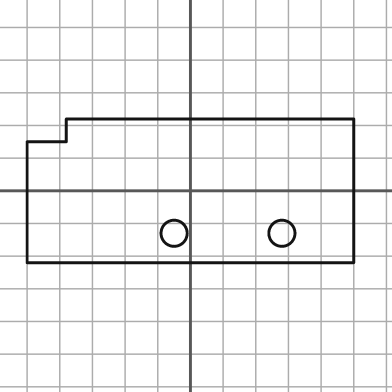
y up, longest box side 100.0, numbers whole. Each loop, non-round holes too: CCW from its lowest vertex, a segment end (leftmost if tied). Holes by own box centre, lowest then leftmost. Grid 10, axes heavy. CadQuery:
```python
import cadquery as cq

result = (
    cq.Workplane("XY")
    .moveTo(-50.0, -22.0)
    .lineTo(50.0, -22.0)
    .lineTo(50.0, 22.0)
    .lineTo(-38.0, 22.0)
    .lineTo(-38.0, 15.0)
    .lineTo(-50.0, 15.0)
    .close()
    .moveTo(-5.0, -13.0)
    .circle(4.0)
    .moveTo(28.0, -13.0)
    .circle(4.0)
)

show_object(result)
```